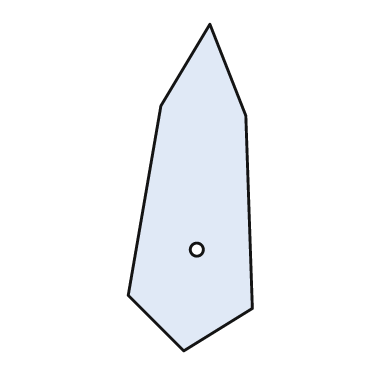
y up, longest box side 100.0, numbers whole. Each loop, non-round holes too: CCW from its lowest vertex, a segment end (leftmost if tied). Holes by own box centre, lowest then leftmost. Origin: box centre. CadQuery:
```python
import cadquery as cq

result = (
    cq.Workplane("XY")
    .moveTo(-2.0, -50.0)
    .lineTo(19.0, -37.0)
    .lineTo(17.0, 22.0)
    .lineTo(6.0, 50.0)
    .lineTo(-9.0, 25.0)
    .lineTo(-19.0, -33.0)
    .close()
    .moveTo(2.0, -19.0)
    .circle(2.0)
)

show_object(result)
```